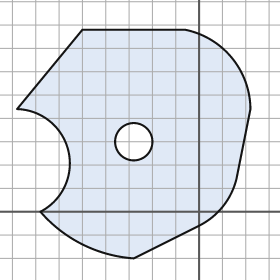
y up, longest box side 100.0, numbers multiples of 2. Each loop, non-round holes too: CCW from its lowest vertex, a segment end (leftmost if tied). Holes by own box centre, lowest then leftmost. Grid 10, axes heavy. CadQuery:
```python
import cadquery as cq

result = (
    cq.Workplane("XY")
    .moveTo(-28.0, -20.0)
    .lineTo(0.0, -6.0)
    .threePointArc((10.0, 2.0), (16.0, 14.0))
    .lineTo(22.0, 44.0)
    .threePointArc((14.0, 66.0), (-6.0, 78.0))
    .lineTo(-50.0, 78.0)
    .lineTo(-78.0, 44.0)
    .threePointArc((-56.0, 26.0), (-68.0, 0.0))
    .threePointArc((-50.0, -14.0), (-28.0, -20.0))
    .close()
    .moveTo(-28.0, 30.0)
    .circle(8.0)
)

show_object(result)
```